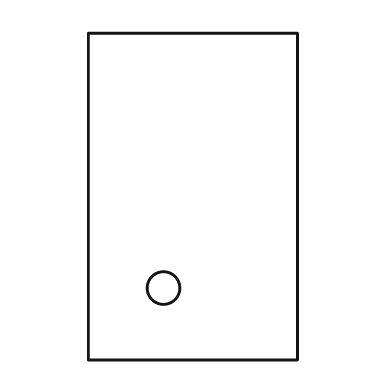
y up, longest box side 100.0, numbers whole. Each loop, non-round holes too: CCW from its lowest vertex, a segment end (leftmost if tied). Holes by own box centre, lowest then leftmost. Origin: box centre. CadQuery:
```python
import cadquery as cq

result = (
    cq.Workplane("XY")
    .moveTo(-32.0, -50.0)
    .lineTo(32.0, -50.0)
    .lineTo(32.0, 50.0)
    .lineTo(-32.0, 50.0)
    .close()
    .moveTo(-9.0, -28.0)
    .circle(5.0)
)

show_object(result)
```